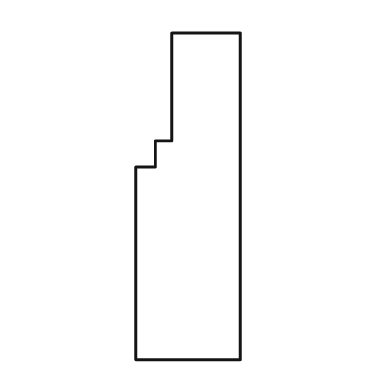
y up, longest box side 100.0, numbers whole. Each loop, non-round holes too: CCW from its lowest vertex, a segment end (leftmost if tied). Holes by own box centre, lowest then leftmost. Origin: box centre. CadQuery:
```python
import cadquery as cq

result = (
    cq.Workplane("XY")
    .moveTo(-16.0, -50.0)
    .lineTo(16.0, -50.0)
    .lineTo(16.0, 50.0)
    .lineTo(-5.0, 50.0)
    .lineTo(-5.0, 17.0)
    .lineTo(-10.0, 17.0)
    .lineTo(-10.0, 9.0)
    .lineTo(-16.0, 9.0)
    .close()
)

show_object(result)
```